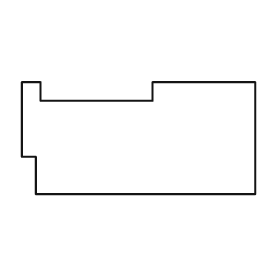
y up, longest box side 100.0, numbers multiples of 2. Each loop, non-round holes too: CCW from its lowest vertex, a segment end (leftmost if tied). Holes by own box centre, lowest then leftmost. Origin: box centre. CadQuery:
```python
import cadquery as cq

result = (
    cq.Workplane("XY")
    .moveTo(-44.0, -24.0)
    .lineTo(50.0, -24.0)
    .lineTo(50.0, 24.0)
    .lineTo(6.0, 24.0)
    .lineTo(6.0, 16.0)
    .lineTo(-42.0, 16.0)
    .lineTo(-42.0, 24.0)
    .lineTo(-50.0, 24.0)
    .lineTo(-50.0, -8.0)
    .lineTo(-44.0, -8.0)
    .close()
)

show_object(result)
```